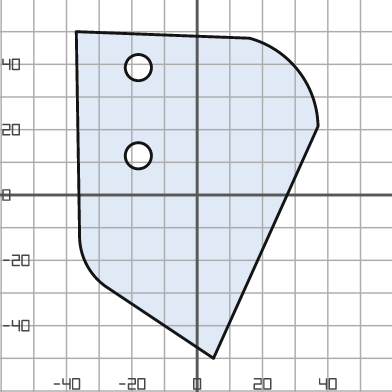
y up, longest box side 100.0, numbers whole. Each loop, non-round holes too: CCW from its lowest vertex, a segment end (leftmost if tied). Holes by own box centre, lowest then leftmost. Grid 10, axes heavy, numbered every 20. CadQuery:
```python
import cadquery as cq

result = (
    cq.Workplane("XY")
    .moveTo(5.0, -50.0)
    .lineTo(37.0, 21.0)
    .threePointArc((31.0, 38.0), (16.0, 48.0))
    .lineTo(-37.0, 50.0)
    .lineTo(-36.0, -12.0)
    .threePointArc((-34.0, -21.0), (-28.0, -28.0))
    .close()
    .moveTo(-18.0, 12.0)
    .circle(4.0)
    .moveTo(-18.0, 39.0)
    .circle(4.0)
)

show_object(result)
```